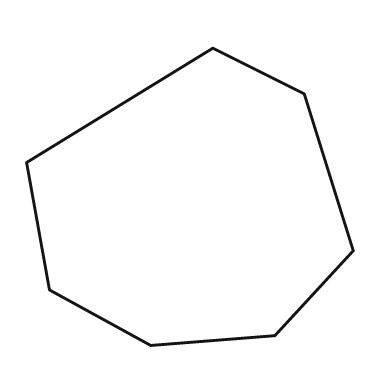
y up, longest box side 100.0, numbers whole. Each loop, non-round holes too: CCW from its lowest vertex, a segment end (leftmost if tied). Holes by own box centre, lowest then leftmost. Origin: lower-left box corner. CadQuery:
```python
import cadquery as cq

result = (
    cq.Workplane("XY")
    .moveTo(38.0, 0.0)
    .lineTo(76.0, 3.0)
    .lineTo(100.0, 29.0)
    .lineTo(85.0, 77.0)
    .lineTo(57.0, 91.0)
    .lineTo(0.0, 56.0)
    .lineTo(7.0, 17.0)
    .close()
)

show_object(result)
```